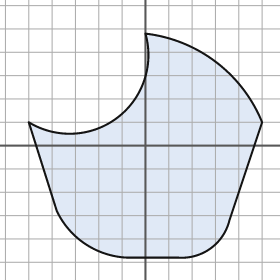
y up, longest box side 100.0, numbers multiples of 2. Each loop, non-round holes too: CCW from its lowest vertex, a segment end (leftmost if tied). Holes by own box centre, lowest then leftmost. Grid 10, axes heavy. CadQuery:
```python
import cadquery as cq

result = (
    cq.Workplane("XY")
    .moveTo(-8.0, -48.0)
    .lineTo(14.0, -48.0)
    .threePointArc((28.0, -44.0), (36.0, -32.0))
    .lineTo(50.0, 10.0)
    .threePointArc((30.0, 36.0), (0.0, 48.0))
    .threePointArc((-12.0, 12.0), (-50.0, 10.0))
    .lineTo(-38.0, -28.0)
    .threePointArc((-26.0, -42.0), (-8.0, -48.0))
    .close()
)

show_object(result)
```